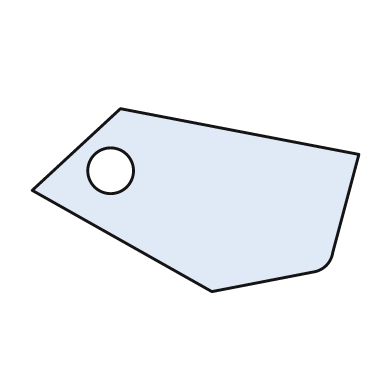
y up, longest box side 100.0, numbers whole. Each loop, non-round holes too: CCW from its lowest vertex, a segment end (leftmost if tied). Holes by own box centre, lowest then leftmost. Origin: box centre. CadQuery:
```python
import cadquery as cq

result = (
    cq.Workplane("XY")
    .moveTo(5.0, -28.0)
    .lineTo(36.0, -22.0)
    .threePointArc((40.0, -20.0), (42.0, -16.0))
    .lineTo(50.0, 14.0)
    .lineTo(-23.0, 28.0)
    .lineTo(-50.0, 3.0)
    .close()
    .moveTo(-26.0, 9.0)
    .circle(7.0)
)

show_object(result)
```